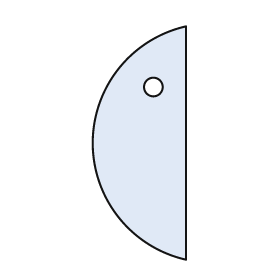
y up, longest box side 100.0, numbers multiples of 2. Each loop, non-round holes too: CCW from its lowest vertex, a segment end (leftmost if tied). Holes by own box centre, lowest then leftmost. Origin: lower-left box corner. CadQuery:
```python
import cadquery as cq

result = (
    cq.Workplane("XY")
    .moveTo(40.0, 0.0)
    .lineTo(40.0, 100.0)
    .threePointArc((0.0, 50.0), (40.0, 0.0))
    .close()
    .moveTo(26.0, 74.0)
    .circle(4.0)
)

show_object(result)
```